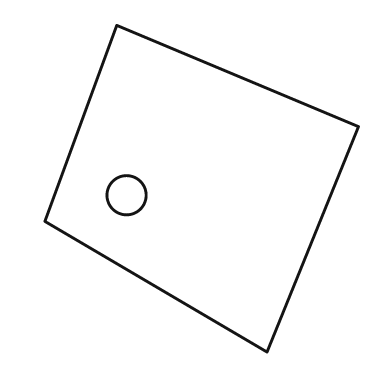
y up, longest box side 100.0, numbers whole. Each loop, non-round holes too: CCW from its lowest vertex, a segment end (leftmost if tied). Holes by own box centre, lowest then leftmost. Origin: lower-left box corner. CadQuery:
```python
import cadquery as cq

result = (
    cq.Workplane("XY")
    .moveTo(68.0, 0.0)
    .lineTo(96.0, 69.0)
    .lineTo(22.0, 100.0)
    .lineTo(0.0, 40.0)
    .close()
    .moveTo(25.0, 48.0)
    .circle(6.0)
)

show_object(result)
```